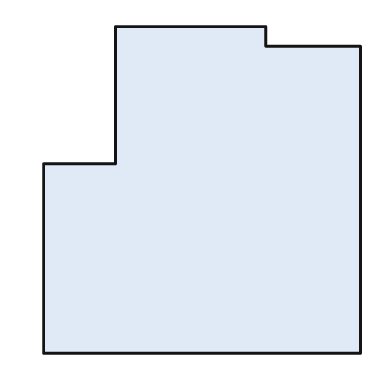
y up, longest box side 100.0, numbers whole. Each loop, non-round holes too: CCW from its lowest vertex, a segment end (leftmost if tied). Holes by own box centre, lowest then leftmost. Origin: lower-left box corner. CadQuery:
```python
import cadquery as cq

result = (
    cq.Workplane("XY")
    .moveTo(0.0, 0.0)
    .lineTo(97.0, 0.0)
    .lineTo(97.0, 94.0)
    .lineTo(68.0, 94.0)
    .lineTo(68.0, 100.0)
    .lineTo(22.0, 100.0)
    .lineTo(22.0, 58.0)
    .lineTo(0.0, 58.0)
    .close()
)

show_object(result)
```